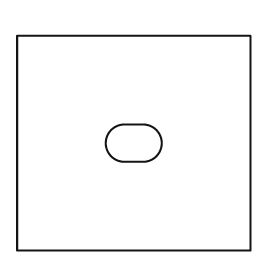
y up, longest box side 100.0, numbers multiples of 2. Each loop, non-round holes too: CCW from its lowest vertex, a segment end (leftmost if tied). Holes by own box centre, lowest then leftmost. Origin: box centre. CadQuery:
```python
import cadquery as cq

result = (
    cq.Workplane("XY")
    .moveTo(-50.0, -46.0)
    .lineTo(50.0, -46.0)
    .lineTo(50.0, 46.0)
    .lineTo(-50.0, 46.0)
    .close()
    .moveTo(-4.0, -8.0)
    .lineTo(4.0, -8.0)
    .threePointArc((12.0, 0.0), (4.0, 8.0))
    .lineTo(-4.0, 8.0)
    .threePointArc((-12.0, 0.0), (-4.0, -8.0))
    .close()
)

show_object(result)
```